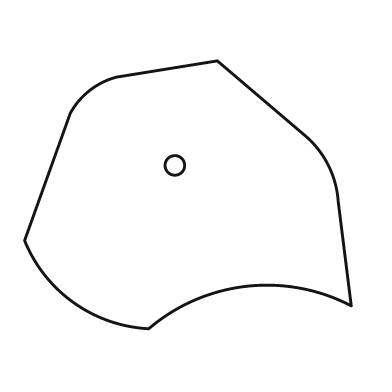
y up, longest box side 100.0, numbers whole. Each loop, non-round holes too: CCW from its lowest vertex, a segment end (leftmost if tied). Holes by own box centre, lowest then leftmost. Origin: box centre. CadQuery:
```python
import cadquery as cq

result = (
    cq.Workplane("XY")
    .moveTo(-12.0, -41.0)
    .threePointArc((18.0, -28.0), (50.0, -34.0))
    .lineTo(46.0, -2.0)
    .threePointArc((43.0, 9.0), (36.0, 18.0))
    .lineTo(9.0, 41.0)
    .lineTo(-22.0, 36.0)
    .threePointArc((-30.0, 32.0), (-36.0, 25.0))
    .lineTo(-50.0, -14.0)
    .threePointArc((-35.0, -33.0), (-12.0, -41.0))
    .close()
    .moveTo(-4.0, 9.0)
    .circle(3.0)
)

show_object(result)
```